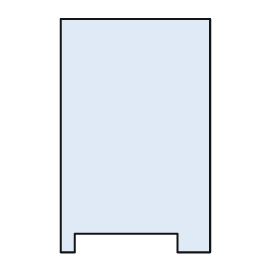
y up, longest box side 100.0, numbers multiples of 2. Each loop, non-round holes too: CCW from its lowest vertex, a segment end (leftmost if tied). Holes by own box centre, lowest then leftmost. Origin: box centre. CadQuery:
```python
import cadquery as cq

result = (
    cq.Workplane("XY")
    .moveTo(-32.0, -50.0)
    .lineTo(-26.0, -50.0)
    .lineTo(-26.0, -42.0)
    .lineTo(18.0, -42.0)
    .lineTo(18.0, -50.0)
    .lineTo(32.0, -50.0)
    .lineTo(32.0, 50.0)
    .lineTo(-32.0, 50.0)
    .close()
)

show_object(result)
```